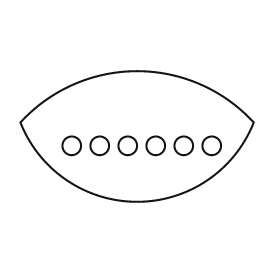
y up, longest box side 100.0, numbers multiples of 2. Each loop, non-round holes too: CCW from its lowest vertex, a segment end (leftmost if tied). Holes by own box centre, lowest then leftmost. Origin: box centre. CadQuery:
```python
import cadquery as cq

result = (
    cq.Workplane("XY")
    .moveTo(-50.0, 6.0)
    .threePointArc((0.0, -28.0), (50.0, 6.0))
    .threePointArc((0.0, 28.0), (-50.0, 6.0))
    .close()
    .moveTo(-28.0, -4.0)
    .circle(4.0)
    .moveTo(-16.0, -4.0)
    .circle(4.0)
    .moveTo(-4.0, -4.0)
    .circle(4.0)
    .moveTo(8.0, -4.0)
    .circle(4.0)
    .moveTo(20.0, -4.0)
    .circle(4.0)
    .moveTo(32.0, -4.0)
    .circle(4.0)
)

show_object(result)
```